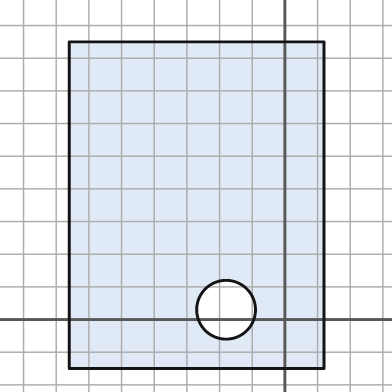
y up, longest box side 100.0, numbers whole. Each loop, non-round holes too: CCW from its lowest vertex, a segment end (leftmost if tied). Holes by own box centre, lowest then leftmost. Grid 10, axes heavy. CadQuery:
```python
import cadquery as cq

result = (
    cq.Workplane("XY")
    .moveTo(-66.0, -15.0)
    .lineTo(12.0, -15.0)
    .lineTo(12.0, 85.0)
    .lineTo(-66.0, 85.0)
    .close()
    .moveTo(-18.0, 3.0)
    .circle(9.0)
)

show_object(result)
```